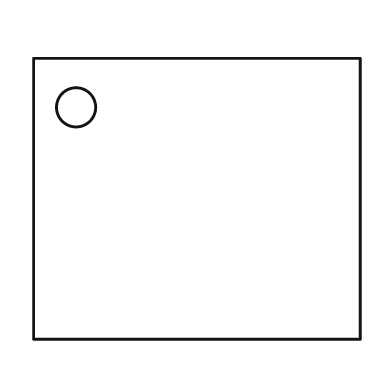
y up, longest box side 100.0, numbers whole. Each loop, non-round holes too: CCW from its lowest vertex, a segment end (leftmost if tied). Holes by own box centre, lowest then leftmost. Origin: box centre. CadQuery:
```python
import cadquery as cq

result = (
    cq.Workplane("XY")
    .moveTo(-50.0, -43.0)
    .lineTo(50.0, -43.0)
    .lineTo(50.0, 43.0)
    .lineTo(-50.0, 43.0)
    .close()
    .moveTo(-37.0, 28.0)
    .circle(6.0)
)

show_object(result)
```